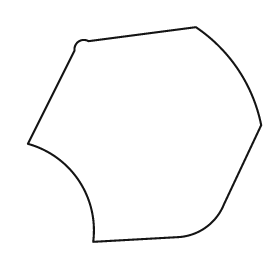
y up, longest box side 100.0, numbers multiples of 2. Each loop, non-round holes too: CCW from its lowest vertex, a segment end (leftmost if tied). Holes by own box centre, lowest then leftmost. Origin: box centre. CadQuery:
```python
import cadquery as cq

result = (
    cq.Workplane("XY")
    .moveTo(-22.0, -46.0)
    .lineTo(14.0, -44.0)
    .threePointArc((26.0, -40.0), (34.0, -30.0))
    .lineTo(50.0, 4.0)
    .threePointArc((40.0, 28.0), (22.0, 46.0))
    .lineTo(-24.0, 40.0)
    .threePointArc((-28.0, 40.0), (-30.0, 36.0))
    .lineTo(-50.0, -4.0)
    .threePointArc((-28.0, -20.0), (-22.0, -46.0))
    .close()
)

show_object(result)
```